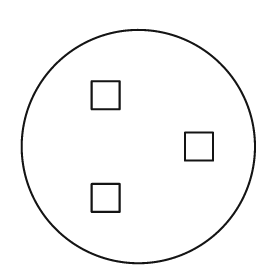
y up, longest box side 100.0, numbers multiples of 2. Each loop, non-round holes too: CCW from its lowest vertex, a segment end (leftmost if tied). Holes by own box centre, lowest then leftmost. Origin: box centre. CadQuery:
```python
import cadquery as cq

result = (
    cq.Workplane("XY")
    .moveTo(0.0, 0.0)
    .circle(50.0)
    .moveTo(-20.0, -28.0)
    .lineTo(-8.0, -28.0)
    .lineTo(-8.0, -16.0)
    .lineTo(-20.0, -16.0)
    .close()
    .moveTo(20.0, -6.0)
    .lineTo(32.0, -6.0)
    .lineTo(32.0, 6.0)
    .lineTo(20.0, 6.0)
    .close()
    .moveTo(-20.0, 16.0)
    .lineTo(-8.0, 16.0)
    .lineTo(-8.0, 28.0)
    .lineTo(-20.0, 28.0)
    .close()
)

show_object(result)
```